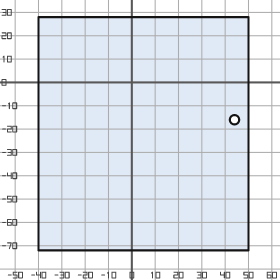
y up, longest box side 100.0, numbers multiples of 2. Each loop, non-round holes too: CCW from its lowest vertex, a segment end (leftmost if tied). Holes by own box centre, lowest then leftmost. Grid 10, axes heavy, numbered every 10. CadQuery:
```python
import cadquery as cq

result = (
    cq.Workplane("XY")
    .moveTo(-40.0, -72.0)
    .lineTo(50.0, -72.0)
    .lineTo(50.0, 28.0)
    .lineTo(-40.0, 28.0)
    .close()
    .moveTo(44.0, -16.0)
    .circle(2.0)
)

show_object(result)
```